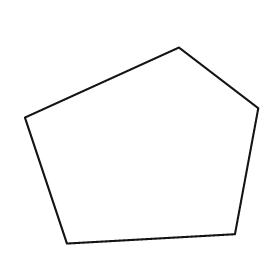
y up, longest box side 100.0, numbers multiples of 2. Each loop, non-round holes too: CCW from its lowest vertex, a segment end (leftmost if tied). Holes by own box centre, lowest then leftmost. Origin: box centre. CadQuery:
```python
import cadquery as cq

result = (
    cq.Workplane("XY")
    .moveTo(-32.0, -42.0)
    .lineTo(40.0, -38.0)
    .lineTo(50.0, 16.0)
    .lineTo(16.0, 42.0)
    .lineTo(-50.0, 12.0)
    .close()
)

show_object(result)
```